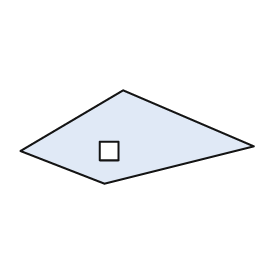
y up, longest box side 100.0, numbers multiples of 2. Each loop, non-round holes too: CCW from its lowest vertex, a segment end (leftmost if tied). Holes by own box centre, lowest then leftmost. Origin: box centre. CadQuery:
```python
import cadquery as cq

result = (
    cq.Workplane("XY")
    .moveTo(-14.0, -20.0)
    .lineTo(50.0, -4.0)
    .lineTo(-6.0, 20.0)
    .lineTo(-50.0, -6.0)
    .close()
    .moveTo(-16.0, -10.0)
    .lineTo(-8.0, -10.0)
    .lineTo(-8.0, -2.0)
    .lineTo(-16.0, -2.0)
    .close()
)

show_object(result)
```